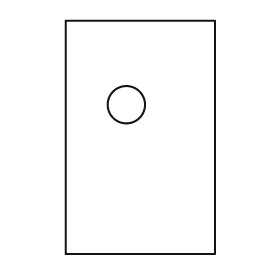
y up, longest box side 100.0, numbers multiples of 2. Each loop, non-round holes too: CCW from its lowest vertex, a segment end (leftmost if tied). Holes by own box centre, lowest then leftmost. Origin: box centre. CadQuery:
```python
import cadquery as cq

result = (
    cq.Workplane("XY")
    .moveTo(-32.0, -50.0)
    .lineTo(32.0, -50.0)
    .lineTo(32.0, 50.0)
    .lineTo(-32.0, 50.0)
    .close()
    .moveTo(-6.0, 14.0)
    .circle(8.0)
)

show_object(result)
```